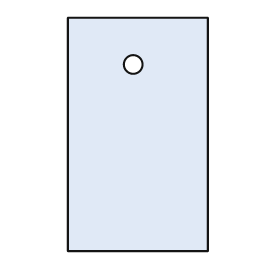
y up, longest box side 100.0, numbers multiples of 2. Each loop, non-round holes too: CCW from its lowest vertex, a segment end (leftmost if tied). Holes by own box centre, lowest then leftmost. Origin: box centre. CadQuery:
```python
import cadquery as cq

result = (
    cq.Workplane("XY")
    .moveTo(-30.0, -50.0)
    .lineTo(30.0, -50.0)
    .lineTo(30.0, 50.0)
    .lineTo(-30.0, 50.0)
    .close()
    .moveTo(-2.0, 30.0)
    .circle(4.0)
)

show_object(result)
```